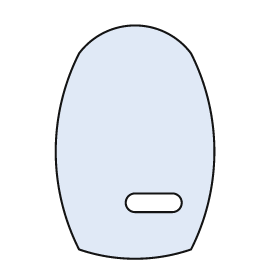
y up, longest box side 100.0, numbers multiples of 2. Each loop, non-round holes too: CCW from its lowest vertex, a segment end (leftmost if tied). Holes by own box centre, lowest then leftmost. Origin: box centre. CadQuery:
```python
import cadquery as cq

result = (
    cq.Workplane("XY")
    .moveTo(-24.0, -46.0)
    .threePointArc((0.0, -50.0), (24.0, -46.0))
    .threePointArc((34.0, -4.0), (24.0, 38.0))
    .threePointArc((0.0, 50.0), (-24.0, 38.0))
    .threePointArc((-34.0, -4.0), (-24.0, -46.0))
    .close()
    .moveTo(0.0, -30.0)
    .lineTo(16.0, -30.0)
    .threePointArc((20.0, -26.0), (16.0, -22.0))
    .lineTo(0.0, -22.0)
    .threePointArc((-4.0, -26.0), (0.0, -30.0))
    .close()
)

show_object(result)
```